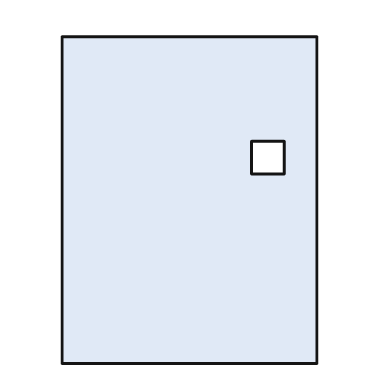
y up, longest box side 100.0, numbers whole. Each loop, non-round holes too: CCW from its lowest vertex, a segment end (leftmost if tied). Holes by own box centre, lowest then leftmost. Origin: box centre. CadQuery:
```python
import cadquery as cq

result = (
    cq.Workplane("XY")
    .moveTo(-39.0, -50.0)
    .lineTo(39.0, -50.0)
    .lineTo(39.0, 50.0)
    .lineTo(-39.0, 50.0)
    .close()
    .moveTo(19.0, 8.0)
    .lineTo(29.0, 8.0)
    .lineTo(29.0, 18.0)
    .lineTo(19.0, 18.0)
    .close()
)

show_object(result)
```